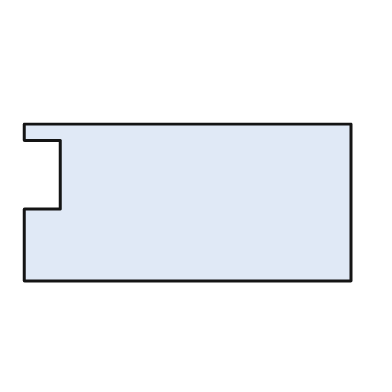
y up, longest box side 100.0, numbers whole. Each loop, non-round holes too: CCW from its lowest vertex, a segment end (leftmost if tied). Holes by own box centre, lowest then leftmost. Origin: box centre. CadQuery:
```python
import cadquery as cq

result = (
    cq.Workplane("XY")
    .moveTo(-50.0, -24.0)
    .lineTo(50.0, -24.0)
    .lineTo(50.0, 24.0)
    .lineTo(-50.0, 24.0)
    .lineTo(-50.0, 19.0)
    .lineTo(-39.0, 19.0)
    .lineTo(-39.0, -2.0)
    .lineTo(-50.0, -2.0)
    .close()
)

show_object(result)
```